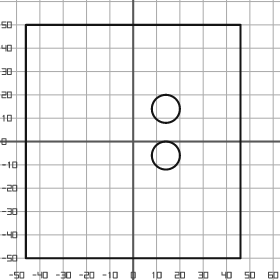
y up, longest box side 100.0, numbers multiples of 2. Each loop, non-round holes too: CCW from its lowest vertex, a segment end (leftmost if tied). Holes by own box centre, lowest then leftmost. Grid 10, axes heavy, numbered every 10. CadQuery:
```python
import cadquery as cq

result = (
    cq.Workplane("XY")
    .moveTo(-46.0, -50.0)
    .lineTo(46.0, -50.0)
    .lineTo(46.0, 50.0)
    .lineTo(-46.0, 50.0)
    .close()
    .moveTo(14.0, -6.0)
    .circle(6.0)
    .moveTo(14.0, 14.0)
    .circle(6.0)
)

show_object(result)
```